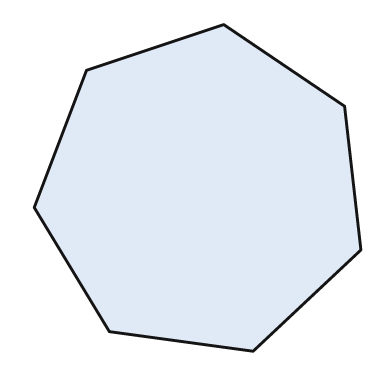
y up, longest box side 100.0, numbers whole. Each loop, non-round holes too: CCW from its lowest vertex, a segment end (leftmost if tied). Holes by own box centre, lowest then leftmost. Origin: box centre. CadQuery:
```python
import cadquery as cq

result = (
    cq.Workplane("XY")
    .moveTo(17.0, -50.0)
    .lineTo(50.0, -19.0)
    .lineTo(45.0, 25.0)
    .lineTo(8.0, 50.0)
    .lineTo(-34.0, 36.0)
    .lineTo(-50.0, -6.0)
    .lineTo(-27.0, -44.0)
    .close()
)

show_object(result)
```